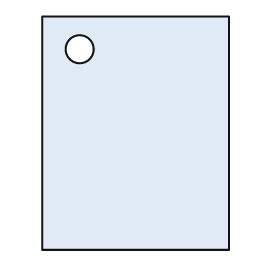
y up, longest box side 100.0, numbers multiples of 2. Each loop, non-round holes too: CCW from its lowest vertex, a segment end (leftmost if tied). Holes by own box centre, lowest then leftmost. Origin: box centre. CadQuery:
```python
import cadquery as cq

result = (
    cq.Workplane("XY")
    .moveTo(-40.0, -50.0)
    .lineTo(40.0, -50.0)
    .lineTo(40.0, 50.0)
    .lineTo(-40.0, 50.0)
    .close()
    .moveTo(-24.0, 36.0)
    .circle(6.0)
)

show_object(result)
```